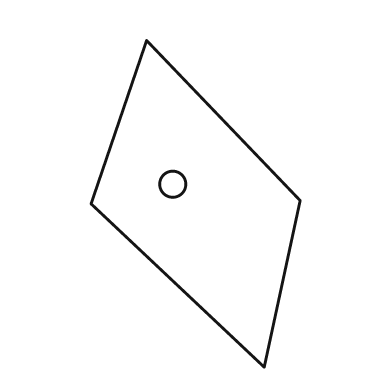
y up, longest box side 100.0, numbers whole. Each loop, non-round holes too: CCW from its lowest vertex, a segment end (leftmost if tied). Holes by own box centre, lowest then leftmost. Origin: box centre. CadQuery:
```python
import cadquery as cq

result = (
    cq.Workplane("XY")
    .moveTo(21.0, -50.0)
    .lineTo(32.0, 1.0)
    .lineTo(-15.0, 50.0)
    .lineTo(-32.0, 0.0)
    .close()
    .moveTo(-7.0, 6.0)
    .circle(4.0)
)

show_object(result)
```